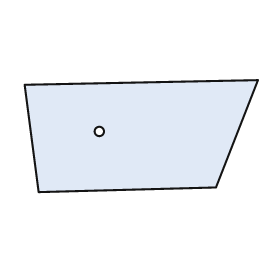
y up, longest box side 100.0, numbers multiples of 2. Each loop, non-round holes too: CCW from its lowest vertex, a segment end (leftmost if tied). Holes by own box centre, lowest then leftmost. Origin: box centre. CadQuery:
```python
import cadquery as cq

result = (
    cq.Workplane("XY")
    .moveTo(-44.0, -24.0)
    .lineTo(32.0, -22.0)
    .lineTo(50.0, 24.0)
    .lineTo(-50.0, 22.0)
    .close()
    .moveTo(-18.0, 2.0)
    .circle(2.0)
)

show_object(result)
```